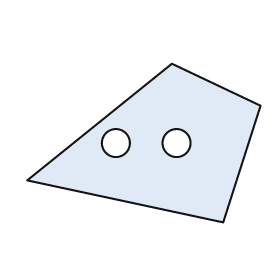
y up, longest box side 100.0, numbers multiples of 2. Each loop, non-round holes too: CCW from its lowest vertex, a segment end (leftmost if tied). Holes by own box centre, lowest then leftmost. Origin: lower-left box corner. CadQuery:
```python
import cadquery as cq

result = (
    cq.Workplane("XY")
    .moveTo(84.0, 0.0)
    .lineTo(100.0, 50.0)
    .lineTo(62.0, 68.0)
    .lineTo(0.0, 18.0)
    .close()
    .moveTo(38.0, 34.0)
    .circle(6.0)
    .moveTo(64.0, 34.0)
    .circle(6.0)
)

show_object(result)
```